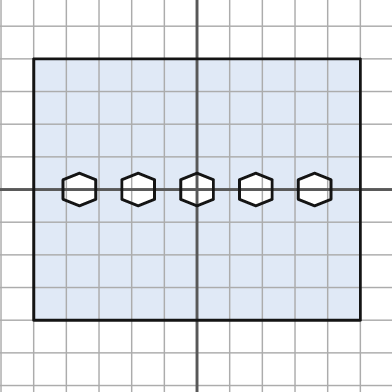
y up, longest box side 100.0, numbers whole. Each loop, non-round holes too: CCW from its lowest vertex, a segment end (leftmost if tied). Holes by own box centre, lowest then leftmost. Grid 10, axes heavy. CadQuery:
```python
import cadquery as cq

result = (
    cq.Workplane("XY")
    .moveTo(-50.0, -40.0)
    .lineTo(50.0, -40.0)
    .lineTo(50.0, 40.0)
    .lineTo(-50.0, 40.0)
    .close()
    .moveTo(-36.0, -5.0)
    .lineTo(-31.0, -3.0)
    .lineTo(-31.0, 3.0)
    .lineTo(-36.0, 5.0)
    .lineTo(-41.0, 3.0)
    .lineTo(-41.0, -3.0)
    .close()
    .moveTo(-18.0, -5.0)
    .lineTo(-13.0, -3.0)
    .lineTo(-13.0, 3.0)
    .lineTo(-18.0, 5.0)
    .lineTo(-23.0, 3.0)
    .lineTo(-23.0, -3.0)
    .close()
    .moveTo(0.0, -5.0)
    .lineTo(5.0, -3.0)
    .lineTo(5.0, 3.0)
    .lineTo(0.0, 5.0)
    .lineTo(-5.0, 3.0)
    .lineTo(-5.0, -3.0)
    .close()
    .moveTo(18.0, -5.0)
    .lineTo(23.0, -3.0)
    .lineTo(23.0, 3.0)
    .lineTo(18.0, 5.0)
    .lineTo(13.0, 3.0)
    .lineTo(13.0, -3.0)
    .close()
    .moveTo(36.0, -5.0)
    .lineTo(41.0, -3.0)
    .lineTo(41.0, 3.0)
    .lineTo(36.0, 5.0)
    .lineTo(31.0, 3.0)
    .lineTo(31.0, -3.0)
    .close()
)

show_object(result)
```